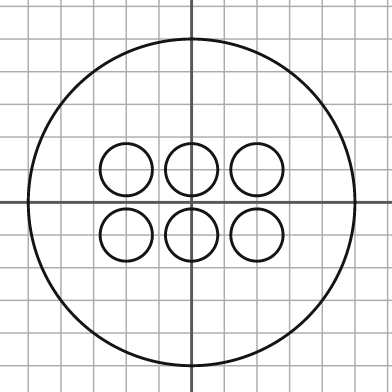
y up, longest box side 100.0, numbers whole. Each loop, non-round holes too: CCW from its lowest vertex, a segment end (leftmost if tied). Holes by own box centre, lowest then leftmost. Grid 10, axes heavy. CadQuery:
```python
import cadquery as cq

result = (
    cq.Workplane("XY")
    .moveTo(0.0, 0.0)
    .circle(50.0)
    .moveTo(-20.0, -10.0)
    .circle(8.0)
    .moveTo(0.0, -10.0)
    .circle(8.0)
    .moveTo(20.0, -10.0)
    .circle(8.0)
    .moveTo(-20.0, 10.0)
    .circle(8.0)
    .moveTo(0.0, 10.0)
    .circle(8.0)
    .moveTo(20.0, 10.0)
    .circle(8.0)
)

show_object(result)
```